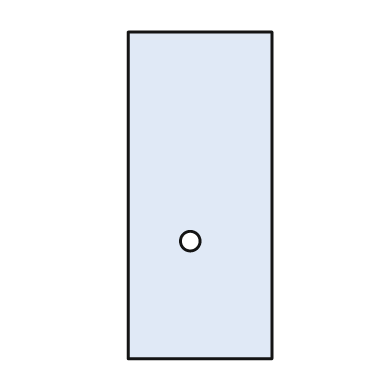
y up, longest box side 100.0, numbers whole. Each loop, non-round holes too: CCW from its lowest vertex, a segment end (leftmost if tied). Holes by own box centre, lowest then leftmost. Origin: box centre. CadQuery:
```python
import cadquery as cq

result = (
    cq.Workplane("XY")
    .moveTo(-22.0, -50.0)
    .lineTo(22.0, -50.0)
    .lineTo(22.0, 50.0)
    .lineTo(-22.0, 50.0)
    .close()
    .moveTo(-3.0, -14.0)
    .circle(3.0)
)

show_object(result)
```